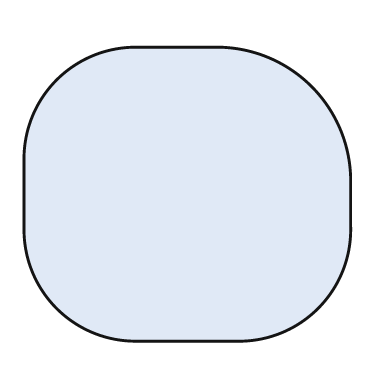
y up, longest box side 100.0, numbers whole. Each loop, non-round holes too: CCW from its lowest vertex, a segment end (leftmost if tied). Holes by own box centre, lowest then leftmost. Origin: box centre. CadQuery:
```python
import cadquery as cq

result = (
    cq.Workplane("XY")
    .moveTo(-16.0, -45.0)
    .lineTo(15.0, -45.0)
    .threePointArc((40.0, -35.0), (50.0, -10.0))
    .lineTo(50.0, 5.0)
    .threePointArc((38.0, 33.0), (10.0, 45.0))
    .lineTo(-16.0, 45.0)
    .threePointArc((-40.0, 35.0), (-50.0, 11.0))
    .lineTo(-50.0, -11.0)
    .threePointArc((-40.0, -35.0), (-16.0, -45.0))
    .close()
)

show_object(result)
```